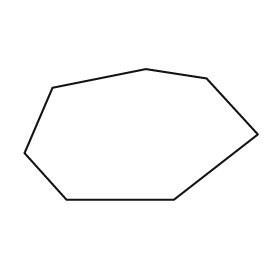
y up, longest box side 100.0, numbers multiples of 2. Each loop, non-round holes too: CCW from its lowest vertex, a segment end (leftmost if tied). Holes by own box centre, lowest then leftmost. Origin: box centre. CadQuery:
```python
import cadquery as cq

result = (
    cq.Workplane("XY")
    .moveTo(-32.0, -28.0)
    .lineTo(14.0, -28.0)
    .lineTo(50.0, 0.0)
    .lineTo(28.0, 24.0)
    .lineTo(2.0, 28.0)
    .lineTo(-38.0, 20.0)
    .lineTo(-50.0, -8.0)
    .close()
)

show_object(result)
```